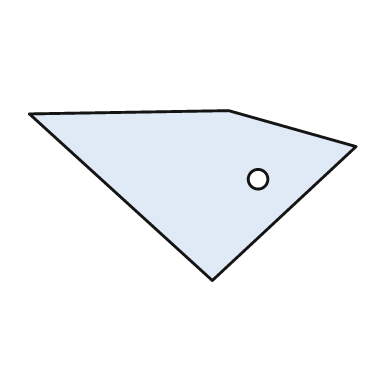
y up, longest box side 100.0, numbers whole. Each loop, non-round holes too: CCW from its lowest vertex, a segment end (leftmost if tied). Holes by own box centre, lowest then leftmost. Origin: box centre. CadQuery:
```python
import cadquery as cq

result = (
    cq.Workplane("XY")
    .moveTo(6.0, -26.0)
    .lineTo(50.0, 15.0)
    .lineTo(11.0, 26.0)
    .lineTo(-50.0, 25.0)
    .close()
    .moveTo(20.0, 5.0)
    .circle(3.0)
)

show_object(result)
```